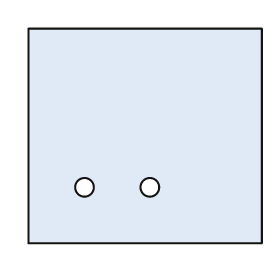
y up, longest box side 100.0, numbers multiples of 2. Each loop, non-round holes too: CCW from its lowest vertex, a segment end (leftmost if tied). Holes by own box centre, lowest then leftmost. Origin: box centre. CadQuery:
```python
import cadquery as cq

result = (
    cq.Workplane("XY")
    .moveTo(-50.0, -46.0)
    .lineTo(50.0, -46.0)
    .lineTo(50.0, 46.0)
    .lineTo(-50.0, 46.0)
    .close()
    .moveTo(-26.0, -22.0)
    .circle(4.0)
    .moveTo(2.0, -22.0)
    .circle(4.0)
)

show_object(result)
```